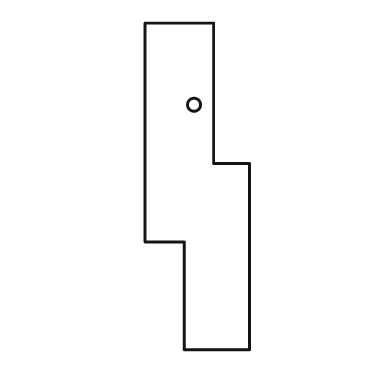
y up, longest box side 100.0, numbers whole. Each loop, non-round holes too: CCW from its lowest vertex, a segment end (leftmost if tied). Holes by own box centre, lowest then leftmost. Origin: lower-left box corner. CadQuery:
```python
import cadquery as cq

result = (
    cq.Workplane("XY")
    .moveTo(12.0, 0.0)
    .lineTo(32.0, 0.0)
    .lineTo(32.0, 57.0)
    .lineTo(21.0, 57.0)
    .lineTo(21.0, 100.0)
    .lineTo(0.0, 100.0)
    .lineTo(0.0, 33.0)
    .lineTo(12.0, 33.0)
    .close()
    .moveTo(15.0, 75.0)
    .circle(2.0)
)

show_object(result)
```